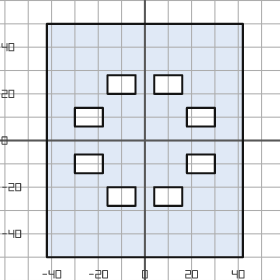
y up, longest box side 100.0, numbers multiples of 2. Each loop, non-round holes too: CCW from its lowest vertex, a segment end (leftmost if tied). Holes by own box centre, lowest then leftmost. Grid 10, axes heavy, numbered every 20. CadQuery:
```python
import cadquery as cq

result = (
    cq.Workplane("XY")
    .moveTo(-42.0, -50.0)
    .lineTo(42.0, -50.0)
    .lineTo(42.0, 50.0)
    .lineTo(-42.0, 50.0)
    .close()
    .moveTo(-16.0, -28.0)
    .lineTo(-4.0, -28.0)
    .lineTo(-4.0, -20.0)
    .lineTo(-16.0, -20.0)
    .close()
    .moveTo(4.0, -28.0)
    .lineTo(16.0, -28.0)
    .lineTo(16.0, -20.0)
    .lineTo(4.0, -20.0)
    .close()
    .moveTo(-30.0, -14.0)
    .lineTo(-18.0, -14.0)
    .lineTo(-18.0, -6.0)
    .lineTo(-30.0, -6.0)
    .close()
    .moveTo(18.0, -14.0)
    .lineTo(30.0, -14.0)
    .lineTo(30.0, -6.0)
    .lineTo(18.0, -6.0)
    .close()
    .moveTo(-30.0, 6.0)
    .lineTo(-18.0, 6.0)
    .lineTo(-18.0, 14.0)
    .lineTo(-30.0, 14.0)
    .close()
    .moveTo(18.0, 6.0)
    .lineTo(30.0, 6.0)
    .lineTo(30.0, 14.0)
    .lineTo(18.0, 14.0)
    .close()
    .moveTo(-16.0, 20.0)
    .lineTo(-4.0, 20.0)
    .lineTo(-4.0, 28.0)
    .lineTo(-16.0, 28.0)
    .close()
    .moveTo(4.0, 20.0)
    .lineTo(16.0, 20.0)
    .lineTo(16.0, 28.0)
    .lineTo(4.0, 28.0)
    .close()
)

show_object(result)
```